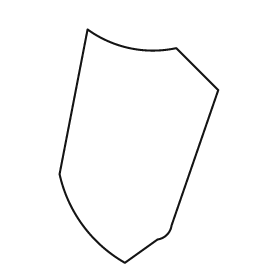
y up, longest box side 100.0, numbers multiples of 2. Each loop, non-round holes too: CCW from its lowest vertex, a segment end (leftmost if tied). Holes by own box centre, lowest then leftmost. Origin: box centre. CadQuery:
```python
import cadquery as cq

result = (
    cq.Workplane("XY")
    .moveTo(-6.0, -50.0)
    .lineTo(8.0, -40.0)
    .threePointArc((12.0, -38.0), (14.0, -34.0))
    .lineTo(34.0, 24.0)
    .lineTo(16.0, 42.0)
    .threePointArc((-4.0, 42.0), (-22.0, 50.0))
    .lineTo(-34.0, -12.0)
    .threePointArc((-24.0, -34.0), (-6.0, -50.0))
    .close()
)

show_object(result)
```